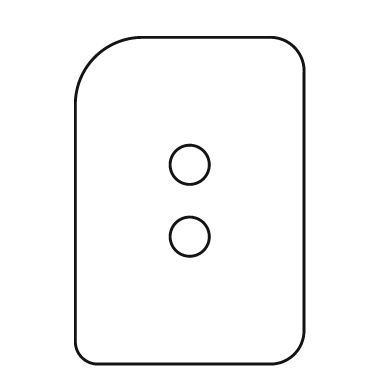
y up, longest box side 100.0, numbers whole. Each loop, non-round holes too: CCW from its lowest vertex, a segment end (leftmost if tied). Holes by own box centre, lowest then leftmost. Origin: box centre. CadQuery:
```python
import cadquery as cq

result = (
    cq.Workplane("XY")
    .moveTo(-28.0, -50.0)
    .lineTo(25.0, -50.0)
    .threePointArc((32.0, -47.0), (35.0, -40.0))
    .lineTo(35.0, 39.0)
    .threePointArc((32.0, 47.0), (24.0, 50.0))
    .lineTo(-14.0, 50.0)
    .threePointArc((-29.0, 44.0), (-35.0, 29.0))
    .lineTo(-35.0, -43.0)
    .threePointArc((-33.0, -48.0), (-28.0, -50.0))
    .close()
    .moveTo(0.0, -11.0)
    .circle(6.0)
    .moveTo(0.0, 11.0)
    .circle(6.0)
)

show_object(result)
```